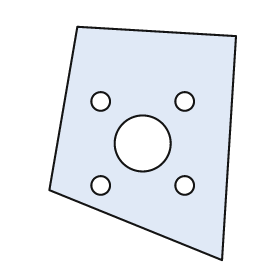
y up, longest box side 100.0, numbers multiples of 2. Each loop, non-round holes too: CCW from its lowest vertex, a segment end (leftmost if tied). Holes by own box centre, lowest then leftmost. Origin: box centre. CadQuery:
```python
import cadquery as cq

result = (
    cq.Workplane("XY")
    .moveTo(34.0, -50.0)
    .lineTo(40.0, 46.0)
    .lineTo(-28.0, 50.0)
    .lineTo(-40.0, -20.0)
    .close()
    .moveTo(-18.0, -18.0)
    .circle(4.0)
    .moveTo(18.0, -18.0)
    .circle(4.0)
    .moveTo(0.0, 0.0)
    .circle(12.0)
    .moveTo(-18.0, 18.0)
    .circle(4.0)
    .moveTo(18.0, 18.0)
    .circle(4.0)
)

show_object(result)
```